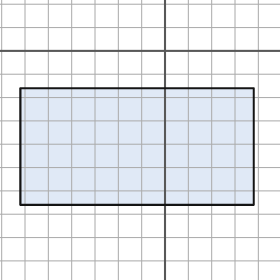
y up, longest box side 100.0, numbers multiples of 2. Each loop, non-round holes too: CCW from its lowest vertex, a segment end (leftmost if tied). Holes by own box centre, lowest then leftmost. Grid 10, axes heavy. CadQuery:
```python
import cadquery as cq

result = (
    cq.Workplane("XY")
    .moveTo(-62.0, -66.0)
    .lineTo(38.0, -66.0)
    .lineTo(38.0, -16.0)
    .lineTo(-62.0, -16.0)
    .close()
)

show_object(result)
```